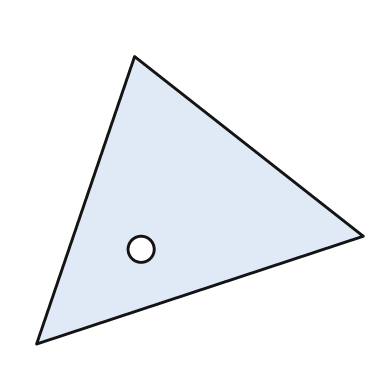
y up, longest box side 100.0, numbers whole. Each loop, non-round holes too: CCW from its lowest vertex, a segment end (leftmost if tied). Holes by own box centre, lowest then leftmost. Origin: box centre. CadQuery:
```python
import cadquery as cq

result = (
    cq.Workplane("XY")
    .moveTo(-50.0, -44.0)
    .lineTo(50.0, -11.0)
    .lineTo(-20.0, 44.0)
    .close()
    .moveTo(-18.0, -15.0)
    .circle(4.0)
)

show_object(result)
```